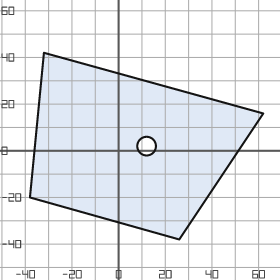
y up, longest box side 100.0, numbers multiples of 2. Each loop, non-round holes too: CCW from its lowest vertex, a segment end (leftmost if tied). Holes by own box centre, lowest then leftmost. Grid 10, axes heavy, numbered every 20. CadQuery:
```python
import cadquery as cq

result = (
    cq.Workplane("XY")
    .moveTo(26.0, -38.0)
    .lineTo(62.0, 16.0)
    .lineTo(-32.0, 42.0)
    .lineTo(-38.0, -20.0)
    .close()
    .moveTo(12.0, 2.0)
    .circle(4.0)
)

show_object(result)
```